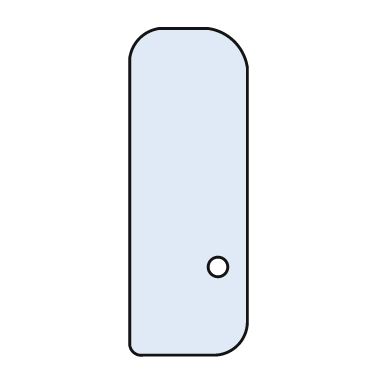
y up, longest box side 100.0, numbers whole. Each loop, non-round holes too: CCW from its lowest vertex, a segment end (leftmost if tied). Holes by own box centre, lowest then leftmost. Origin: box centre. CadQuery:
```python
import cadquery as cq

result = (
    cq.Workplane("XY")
    .moveTo(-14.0, -50.0)
    .lineTo(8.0, -50.0)
    .threePointArc((15.0, -47.0), (18.0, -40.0))
    .lineTo(18.0, 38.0)
    .threePointArc((14.0, 46.0), (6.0, 50.0))
    .lineTo(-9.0, 50.0)
    .threePointArc((-15.0, 47.0), (-18.0, 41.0))
    .lineTo(-18.0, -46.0)
    .threePointArc((-17.0, -49.0), (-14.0, -50.0))
    .close()
    .moveTo(9.0, -23.0)
    .circle(3.0)
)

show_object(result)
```